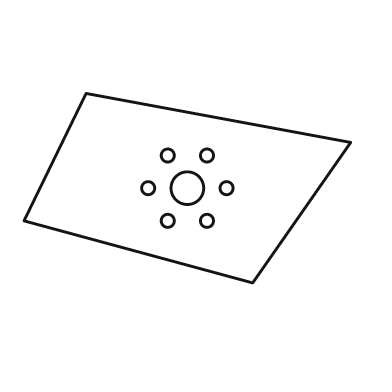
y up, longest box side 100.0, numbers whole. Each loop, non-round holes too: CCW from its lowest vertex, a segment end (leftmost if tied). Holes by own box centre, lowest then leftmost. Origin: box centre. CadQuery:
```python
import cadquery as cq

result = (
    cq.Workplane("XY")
    .moveTo(20.0, -29.0)
    .lineTo(50.0, 14.0)
    .lineTo(-31.0, 29.0)
    .lineTo(-50.0, -10.0)
    .close()
    .moveTo(-6.0, -10.0)
    .circle(2.0)
    .moveTo(6.0, -10.0)
    .circle(2.0)
    .moveTo(-12.0, 0.0)
    .circle(2.0)
    .moveTo(0.0, 0.0)
    .circle(5.0)
    .moveTo(12.0, 0.0)
    .circle(2.0)
    .moveTo(-6.0, 10.0)
    .circle(2.0)
    .moveTo(6.0, 10.0)
    .circle(2.0)
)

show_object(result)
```